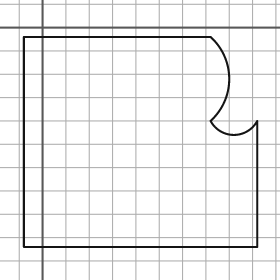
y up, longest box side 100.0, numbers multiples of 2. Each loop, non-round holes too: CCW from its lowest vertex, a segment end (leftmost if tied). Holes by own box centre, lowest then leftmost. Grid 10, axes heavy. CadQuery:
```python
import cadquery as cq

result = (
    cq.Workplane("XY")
    .moveTo(-8.0, -94.0)
    .lineTo(92.0, -94.0)
    .lineTo(92.0, -40.0)
    .threePointArc((82.0, -46.0), (72.0, -40.0))
    .threePointArc((80.0, -22.0), (72.0, -4.0))
    .lineTo(-8.0, -4.0)
    .close()
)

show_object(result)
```